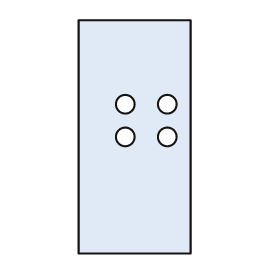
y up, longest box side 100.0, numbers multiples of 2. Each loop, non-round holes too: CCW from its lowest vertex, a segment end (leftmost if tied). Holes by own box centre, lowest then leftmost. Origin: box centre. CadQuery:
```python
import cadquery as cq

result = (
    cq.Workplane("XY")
    .moveTo(-24.0, -50.0)
    .lineTo(24.0, -50.0)
    .lineTo(24.0, 50.0)
    .lineTo(-24.0, 50.0)
    .close()
    .moveTo(-4.0, 0.0)
    .circle(4.0)
    .moveTo(14.0, 0.0)
    .circle(4.0)
    .moveTo(-4.0, 14.0)
    .circle(4.0)
    .moveTo(14.0, 14.0)
    .circle(4.0)
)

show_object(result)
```